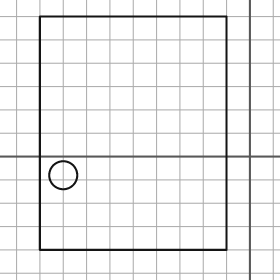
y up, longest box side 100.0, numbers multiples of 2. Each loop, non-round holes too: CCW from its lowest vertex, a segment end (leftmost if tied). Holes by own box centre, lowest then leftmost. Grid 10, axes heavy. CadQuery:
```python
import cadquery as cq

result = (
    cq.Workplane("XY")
    .moveTo(-90.0, -40.0)
    .lineTo(-10.0, -40.0)
    .lineTo(-10.0, 60.0)
    .lineTo(-90.0, 60.0)
    .close()
    .moveTo(-80.0, -8.0)
    .circle(6.0)
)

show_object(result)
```